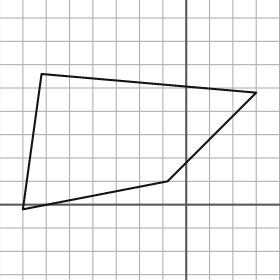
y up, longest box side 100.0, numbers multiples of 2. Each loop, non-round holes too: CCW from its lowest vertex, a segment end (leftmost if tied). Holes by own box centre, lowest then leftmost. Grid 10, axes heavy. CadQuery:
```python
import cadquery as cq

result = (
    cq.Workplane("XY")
    .moveTo(-70.0, -2.0)
    .lineTo(-8.0, 10.0)
    .lineTo(30.0, 48.0)
    .lineTo(-62.0, 56.0)
    .close()
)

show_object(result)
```